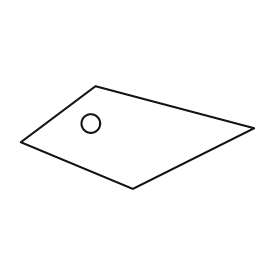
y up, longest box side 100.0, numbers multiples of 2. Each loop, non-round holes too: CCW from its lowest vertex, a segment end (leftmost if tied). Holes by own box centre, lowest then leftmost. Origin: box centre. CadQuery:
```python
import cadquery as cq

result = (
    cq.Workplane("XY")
    .moveTo(-2.0, -22.0)
    .lineTo(50.0, 4.0)
    .lineTo(-18.0, 22.0)
    .lineTo(-50.0, -2.0)
    .close()
    .moveTo(-20.0, 6.0)
    .circle(4.0)
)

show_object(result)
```